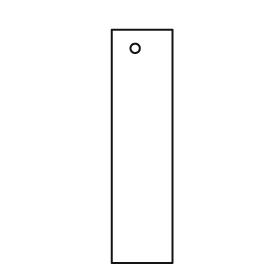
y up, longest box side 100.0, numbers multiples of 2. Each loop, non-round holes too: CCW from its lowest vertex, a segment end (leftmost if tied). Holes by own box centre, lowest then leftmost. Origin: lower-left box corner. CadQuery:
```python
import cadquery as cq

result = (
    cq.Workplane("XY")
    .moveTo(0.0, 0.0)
    .lineTo(26.0, 0.0)
    .lineTo(26.0, 100.0)
    .lineTo(0.0, 100.0)
    .close()
    .moveTo(10.0, 92.0)
    .circle(2.0)
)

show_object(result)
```